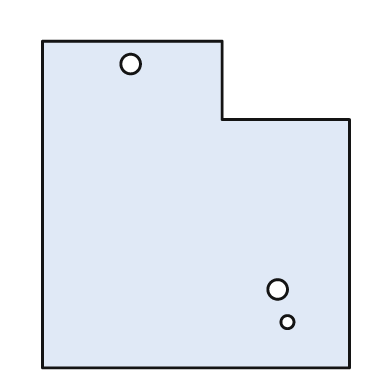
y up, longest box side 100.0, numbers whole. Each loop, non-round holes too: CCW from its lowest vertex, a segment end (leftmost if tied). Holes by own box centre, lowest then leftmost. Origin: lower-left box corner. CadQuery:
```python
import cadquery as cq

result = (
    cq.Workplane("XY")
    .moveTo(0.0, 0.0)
    .lineTo(94.0, 0.0)
    .lineTo(94.0, 76.0)
    .lineTo(55.0, 76.0)
    .lineTo(55.0, 100.0)
    .lineTo(0.0, 100.0)
    .close()
    .moveTo(75.0, 14.0)
    .circle(2.0)
    .moveTo(72.0, 24.0)
    .circle(3.0)
    .moveTo(27.0, 93.0)
    .circle(3.0)
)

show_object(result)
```